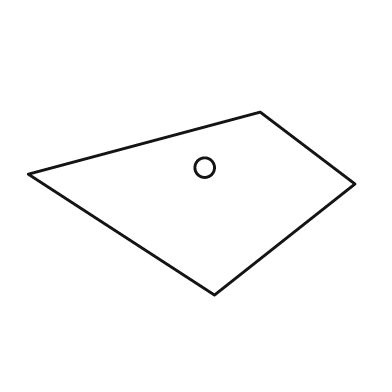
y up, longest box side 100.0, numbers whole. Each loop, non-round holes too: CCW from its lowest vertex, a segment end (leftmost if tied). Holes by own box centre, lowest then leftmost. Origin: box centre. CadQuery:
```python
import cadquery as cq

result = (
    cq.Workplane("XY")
    .moveTo(7.0, -28.0)
    .lineTo(50.0, 6.0)
    .lineTo(21.0, 28.0)
    .lineTo(-50.0, 9.0)
    .close()
    .moveTo(4.0, 11.0)
    .circle(3.0)
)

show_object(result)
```